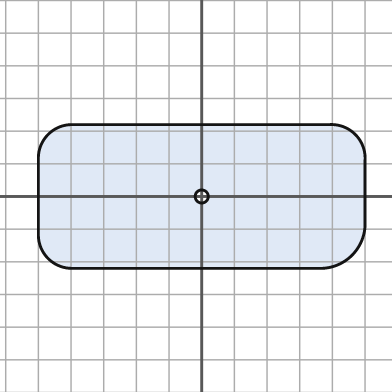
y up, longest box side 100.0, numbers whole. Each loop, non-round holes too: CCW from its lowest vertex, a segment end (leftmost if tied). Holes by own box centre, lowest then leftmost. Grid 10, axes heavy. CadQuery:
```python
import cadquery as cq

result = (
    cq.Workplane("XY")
    .moveTo(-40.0, -22.0)
    .lineTo(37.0, -22.0)
    .threePointArc((46.0, -18.0), (50.0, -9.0))
    .lineTo(50.0, 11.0)
    .threePointArc((47.0, 19.0), (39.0, 22.0))
    .lineTo(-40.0, 22.0)
    .threePointArc((-47.0, 19.0), (-50.0, 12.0))
    .lineTo(-50.0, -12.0)
    .threePointArc((-47.0, -19.0), (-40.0, -22.0))
    .close()
    .moveTo(0.0, 0.0)
    .circle(2.0)
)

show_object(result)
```